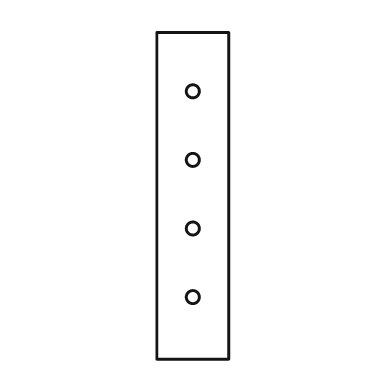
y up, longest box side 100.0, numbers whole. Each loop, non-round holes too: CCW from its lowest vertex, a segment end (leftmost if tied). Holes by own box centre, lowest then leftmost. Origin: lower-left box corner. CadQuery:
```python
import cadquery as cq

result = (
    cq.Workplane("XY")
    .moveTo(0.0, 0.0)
    .lineTo(22.0, 0.0)
    .lineTo(22.0, 100.0)
    .lineTo(0.0, 100.0)
    .close()
    .moveTo(11.0, 19.0)
    .circle(2.0)
    .moveTo(11.0, 40.0)
    .circle(2.0)
    .moveTo(11.0, 61.0)
    .circle(2.0)
    .moveTo(11.0, 82.0)
    .circle(2.0)
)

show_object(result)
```